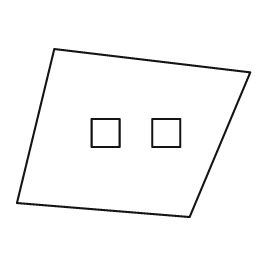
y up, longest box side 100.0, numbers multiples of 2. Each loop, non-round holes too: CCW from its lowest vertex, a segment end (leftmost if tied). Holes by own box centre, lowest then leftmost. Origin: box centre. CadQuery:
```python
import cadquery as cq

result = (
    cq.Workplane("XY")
    .moveTo(24.0, -36.0)
    .lineTo(50.0, 26.0)
    .lineTo(-34.0, 36.0)
    .lineTo(-50.0, -30.0)
    .close()
    .moveTo(-18.0, -6.0)
    .lineTo(-6.0, -6.0)
    .lineTo(-6.0, 6.0)
    .lineTo(-18.0, 6.0)
    .close()
    .moveTo(8.0, -6.0)
    .lineTo(20.0, -6.0)
    .lineTo(20.0, 6.0)
    .lineTo(8.0, 6.0)
    .close()
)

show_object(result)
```